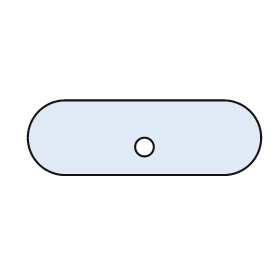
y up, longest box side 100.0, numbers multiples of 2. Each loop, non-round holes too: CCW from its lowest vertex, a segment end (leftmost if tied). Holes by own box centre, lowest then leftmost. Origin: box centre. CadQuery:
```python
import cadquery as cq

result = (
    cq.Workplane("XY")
    .moveTo(-34.0, -16.0)
    .lineTo(34.0, -16.0)
    .threePointArc((50.0, 0.0), (34.0, 16.0))
    .lineTo(-34.0, 16.0)
    .threePointArc((-50.0, 0.0), (-34.0, -16.0))
    .close()
    .moveTo(0.0, -4.0)
    .circle(4.0)
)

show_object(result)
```